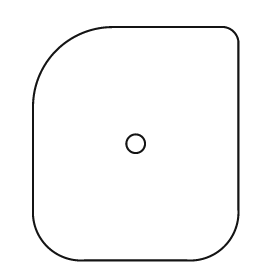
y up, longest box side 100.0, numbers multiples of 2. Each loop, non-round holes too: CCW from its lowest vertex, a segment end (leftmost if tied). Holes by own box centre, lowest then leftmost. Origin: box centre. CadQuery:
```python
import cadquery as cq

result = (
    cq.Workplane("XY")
    .moveTo(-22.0, -50.0)
    .lineTo(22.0, -50.0)
    .threePointArc((38.0, -44.0), (44.0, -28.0))
    .lineTo(44.0, 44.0)
    .threePointArc((42.0, 48.0), (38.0, 50.0))
    .lineTo(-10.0, 50.0)
    .threePointArc((-34.0, 40.0), (-44.0, 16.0))
    .lineTo(-44.0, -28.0)
    .threePointArc((-38.0, -44.0), (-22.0, -50.0))
    .close()
    .moveTo(0.0, 0.0)
    .circle(4.0)
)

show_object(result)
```